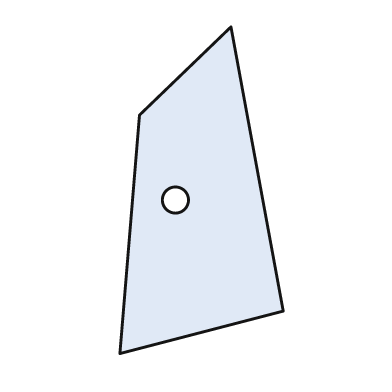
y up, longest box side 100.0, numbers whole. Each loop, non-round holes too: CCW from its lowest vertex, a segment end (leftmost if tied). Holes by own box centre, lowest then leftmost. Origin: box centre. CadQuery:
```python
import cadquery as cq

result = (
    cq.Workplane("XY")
    .moveTo(-25.0, -50.0)
    .lineTo(25.0, -37.0)
    .lineTo(9.0, 50.0)
    .lineTo(-19.0, 23.0)
    .close()
    .moveTo(-8.0, -3.0)
    .circle(4.0)
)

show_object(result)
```